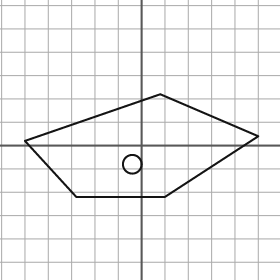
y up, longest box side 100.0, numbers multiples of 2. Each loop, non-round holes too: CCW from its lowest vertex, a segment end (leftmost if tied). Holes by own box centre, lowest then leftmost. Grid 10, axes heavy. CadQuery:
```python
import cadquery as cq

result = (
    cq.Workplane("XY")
    .moveTo(-28.0, -22.0)
    .lineTo(10.0, -22.0)
    .lineTo(50.0, 4.0)
    .lineTo(8.0, 22.0)
    .lineTo(-50.0, 2.0)
    .close()
    .moveTo(-4.0, -8.0)
    .circle(4.0)
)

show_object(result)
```